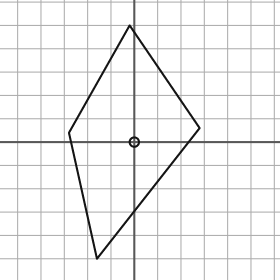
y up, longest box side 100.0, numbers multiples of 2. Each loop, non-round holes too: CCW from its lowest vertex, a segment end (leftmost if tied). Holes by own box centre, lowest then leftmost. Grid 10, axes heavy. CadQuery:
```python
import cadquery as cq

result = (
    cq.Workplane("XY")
    .moveTo(-16.0, -50.0)
    .lineTo(28.0, 6.0)
    .lineTo(-2.0, 50.0)
    .lineTo(-28.0, 4.0)
    .close()
    .moveTo(0.0, 0.0)
    .circle(2.0)
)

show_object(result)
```